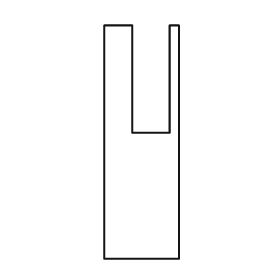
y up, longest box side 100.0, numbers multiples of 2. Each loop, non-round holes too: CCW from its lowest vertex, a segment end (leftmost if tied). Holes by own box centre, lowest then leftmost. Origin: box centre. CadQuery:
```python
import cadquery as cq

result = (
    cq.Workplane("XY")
    .moveTo(-16.0, -50.0)
    .lineTo(16.0, -50.0)
    .lineTo(16.0, 50.0)
    .lineTo(12.0, 50.0)
    .lineTo(12.0, 4.0)
    .lineTo(-4.0, 4.0)
    .lineTo(-4.0, 50.0)
    .lineTo(-16.0, 50.0)
    .close()
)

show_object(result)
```